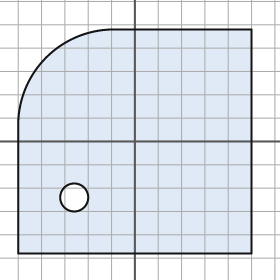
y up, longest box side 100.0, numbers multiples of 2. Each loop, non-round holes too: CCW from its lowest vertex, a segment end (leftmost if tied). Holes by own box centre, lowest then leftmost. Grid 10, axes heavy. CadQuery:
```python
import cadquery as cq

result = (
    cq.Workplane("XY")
    .moveTo(-50.0, -48.0)
    .lineTo(50.0, -48.0)
    .lineTo(50.0, 48.0)
    .lineTo(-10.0, 48.0)
    .threePointArc((-38.0, 36.0), (-50.0, 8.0))
    .close()
    .moveTo(-26.0, -24.0)
    .circle(6.0)
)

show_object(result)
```